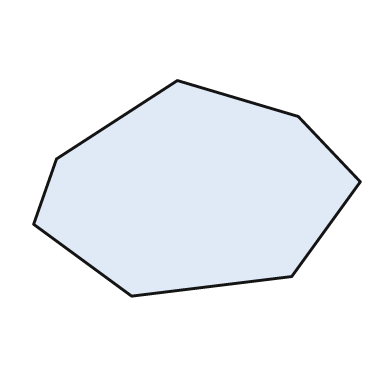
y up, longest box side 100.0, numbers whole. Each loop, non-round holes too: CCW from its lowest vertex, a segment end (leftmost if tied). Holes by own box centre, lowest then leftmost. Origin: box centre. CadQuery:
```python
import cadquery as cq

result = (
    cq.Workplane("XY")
    .moveTo(-20.0, -33.0)
    .lineTo(29.0, -27.0)
    .lineTo(50.0, 2.0)
    .lineTo(31.0, 22.0)
    .lineTo(-6.0, 33.0)
    .lineTo(-43.0, 9.0)
    .lineTo(-50.0, -11.0)
    .close()
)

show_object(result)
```